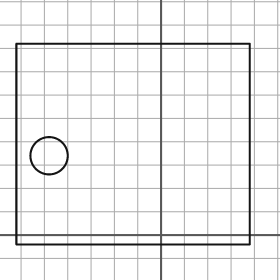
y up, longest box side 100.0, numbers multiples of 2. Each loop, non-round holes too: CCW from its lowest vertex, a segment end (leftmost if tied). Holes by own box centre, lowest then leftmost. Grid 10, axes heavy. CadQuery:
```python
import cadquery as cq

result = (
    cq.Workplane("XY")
    .moveTo(-62.0, -4.0)
    .lineTo(38.0, -4.0)
    .lineTo(38.0, 82.0)
    .lineTo(-62.0, 82.0)
    .close()
    .moveTo(-48.0, 34.0)
    .circle(8.0)
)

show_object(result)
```